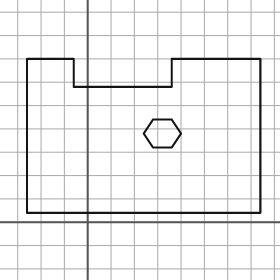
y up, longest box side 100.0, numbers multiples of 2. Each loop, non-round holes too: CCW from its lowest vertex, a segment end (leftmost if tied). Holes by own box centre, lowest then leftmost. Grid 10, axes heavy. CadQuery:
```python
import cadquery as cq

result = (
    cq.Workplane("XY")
    .moveTo(-26.0, 4.0)
    .lineTo(74.0, 4.0)
    .lineTo(74.0, 70.0)
    .lineTo(36.0, 70.0)
    .lineTo(36.0, 58.0)
    .lineTo(-6.0, 58.0)
    .lineTo(-6.0, 70.0)
    .lineTo(-26.0, 70.0)
    .close()
    .moveTo(28.0, 32.0)
    .lineTo(36.0, 32.0)
    .lineTo(40.0, 38.0)
    .lineTo(36.0, 44.0)
    .lineTo(28.0, 44.0)
    .lineTo(24.0, 38.0)
    .close()
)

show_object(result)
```